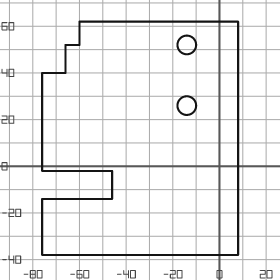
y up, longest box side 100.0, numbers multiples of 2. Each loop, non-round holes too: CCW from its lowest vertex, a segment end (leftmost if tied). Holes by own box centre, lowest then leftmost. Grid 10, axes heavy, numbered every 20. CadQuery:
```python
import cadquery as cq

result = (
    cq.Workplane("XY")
    .moveTo(-76.0, -38.0)
    .lineTo(8.0, -38.0)
    .lineTo(8.0, 62.0)
    .lineTo(-60.0, 62.0)
    .lineTo(-60.0, 52.0)
    .lineTo(-66.0, 52.0)
    .lineTo(-66.0, 40.0)
    .lineTo(-76.0, 40.0)
    .lineTo(-76.0, -2.0)
    .lineTo(-46.0, -2.0)
    .lineTo(-46.0, -14.0)
    .lineTo(-76.0, -14.0)
    .close()
    .moveTo(-14.0, 26.0)
    .circle(4.0)
    .moveTo(-14.0, 52.0)
    .circle(4.0)
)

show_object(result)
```